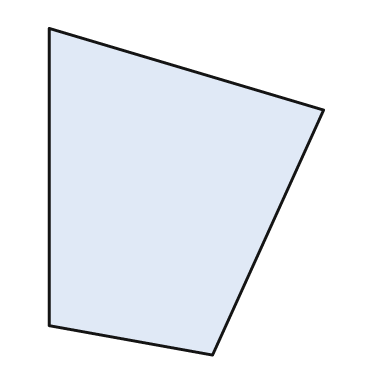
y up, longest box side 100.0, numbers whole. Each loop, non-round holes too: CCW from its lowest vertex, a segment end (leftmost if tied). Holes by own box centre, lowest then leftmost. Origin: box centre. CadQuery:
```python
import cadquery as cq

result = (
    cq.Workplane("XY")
    .moveTo(8.0, -50.0)
    .lineTo(42.0, 25.0)
    .lineTo(-42.0, 50.0)
    .lineTo(-42.0, -41.0)
    .close()
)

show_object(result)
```